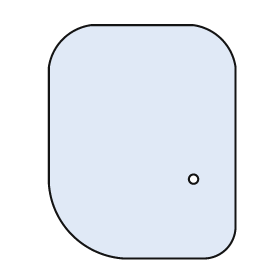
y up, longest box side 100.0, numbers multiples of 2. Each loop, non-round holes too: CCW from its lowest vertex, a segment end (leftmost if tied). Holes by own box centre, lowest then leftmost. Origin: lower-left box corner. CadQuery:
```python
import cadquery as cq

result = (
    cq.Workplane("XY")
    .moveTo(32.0, 0.0)
    .lineTo(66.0, 0.0)
    .threePointArc((76.0, 4.0), (80.0, 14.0))
    .lineTo(80.0, 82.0)
    .threePointArc((74.0, 94.0), (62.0, 100.0))
    .lineTo(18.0, 100.0)
    .threePointArc((6.0, 94.0), (0.0, 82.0))
    .lineTo(0.0, 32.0)
    .threePointArc((10.0, 10.0), (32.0, 0.0))
    .close()
    .moveTo(62.0, 34.0)
    .circle(2.0)
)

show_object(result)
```